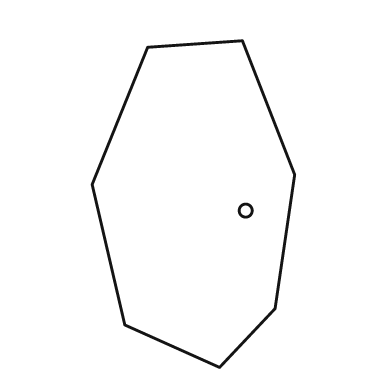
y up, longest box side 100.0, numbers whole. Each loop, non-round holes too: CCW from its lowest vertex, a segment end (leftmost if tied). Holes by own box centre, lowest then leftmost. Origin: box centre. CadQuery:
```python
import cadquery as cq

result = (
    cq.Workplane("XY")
    .moveTo(8.0, -50.0)
    .lineTo(25.0, -32.0)
    .lineTo(31.0, 9.0)
    .lineTo(15.0, 50.0)
    .lineTo(-14.0, 48.0)
    .lineTo(-31.0, 6.0)
    .lineTo(-21.0, -37.0)
    .close()
    .moveTo(16.0, -2.0)
    .circle(2.0)
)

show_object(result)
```